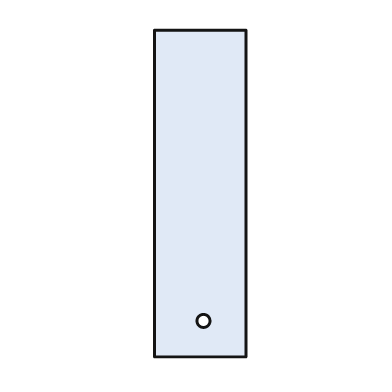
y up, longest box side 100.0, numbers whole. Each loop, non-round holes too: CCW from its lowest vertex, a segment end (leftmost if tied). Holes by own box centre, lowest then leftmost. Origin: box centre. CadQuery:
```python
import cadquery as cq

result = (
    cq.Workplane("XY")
    .moveTo(-14.0, -50.0)
    .lineTo(14.0, -50.0)
    .lineTo(14.0, 50.0)
    .lineTo(-14.0, 50.0)
    .close()
    .moveTo(1.0, -39.0)
    .circle(2.0)
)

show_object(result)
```